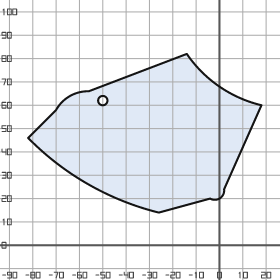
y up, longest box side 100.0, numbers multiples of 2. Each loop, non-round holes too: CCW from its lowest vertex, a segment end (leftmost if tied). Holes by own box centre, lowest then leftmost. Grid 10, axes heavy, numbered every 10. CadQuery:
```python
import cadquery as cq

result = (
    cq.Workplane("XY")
    .moveTo(-26.0, 14.0)
    .lineTo(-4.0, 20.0)
    .threePointArc((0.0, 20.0), (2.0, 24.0))
    .lineTo(18.0, 60.0)
    .threePointArc((0.0, 68.0), (-14.0, 82.0))
    .lineTo(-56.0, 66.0)
    .threePointArc((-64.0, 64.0), (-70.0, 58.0))
    .lineTo(-82.0, 46.0)
    .threePointArc((-56.0, 26.0), (-26.0, 14.0))
    .close()
    .moveTo(-50.0, 62.0)
    .circle(2.0)
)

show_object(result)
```